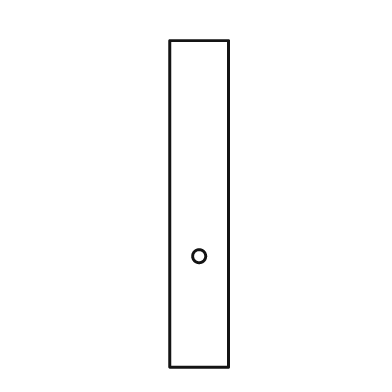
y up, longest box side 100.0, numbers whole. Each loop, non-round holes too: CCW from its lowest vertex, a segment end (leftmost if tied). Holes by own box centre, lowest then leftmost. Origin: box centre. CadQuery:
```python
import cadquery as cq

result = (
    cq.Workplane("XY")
    .moveTo(-9.0, -50.0)
    .lineTo(9.0, -50.0)
    .lineTo(9.0, 50.0)
    .lineTo(-9.0, 50.0)
    .close()
    .moveTo(0.0, -16.0)
    .circle(2.0)
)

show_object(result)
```